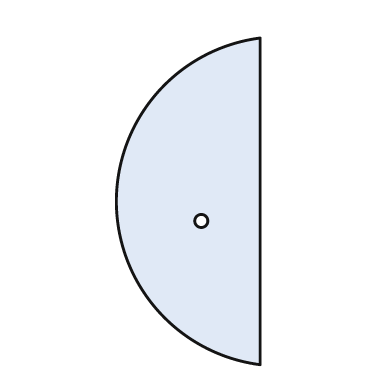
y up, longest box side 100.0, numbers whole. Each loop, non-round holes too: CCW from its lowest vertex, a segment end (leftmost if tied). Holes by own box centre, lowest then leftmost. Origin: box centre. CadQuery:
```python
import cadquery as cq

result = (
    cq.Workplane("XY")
    .moveTo(22.0, -50.0)
    .lineTo(22.0, 50.0)
    .threePointArc((-22.0, 0.0), (22.0, -50.0))
    .close()
    .moveTo(4.0, -6.0)
    .circle(2.0)
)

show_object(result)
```